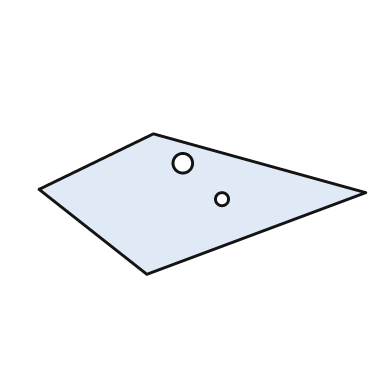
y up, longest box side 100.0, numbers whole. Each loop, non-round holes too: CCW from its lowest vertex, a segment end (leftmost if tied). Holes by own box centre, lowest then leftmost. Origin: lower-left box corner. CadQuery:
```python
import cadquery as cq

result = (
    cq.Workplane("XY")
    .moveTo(33.0, 0.0)
    .lineTo(100.0, 25.0)
    .lineTo(35.0, 43.0)
    .lineTo(0.0, 26.0)
    .close()
    .moveTo(56.0, 23.0)
    .circle(2.0)
    .moveTo(44.0, 34.0)
    .circle(3.0)
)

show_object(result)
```